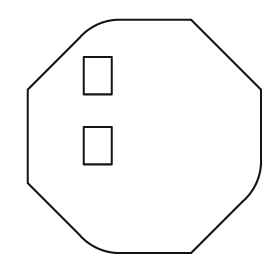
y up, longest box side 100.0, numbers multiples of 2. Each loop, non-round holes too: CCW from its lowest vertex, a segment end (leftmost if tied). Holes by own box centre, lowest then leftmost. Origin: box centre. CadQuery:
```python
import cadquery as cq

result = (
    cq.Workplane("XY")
    .moveTo(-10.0, -50.0)
    .lineTo(20.0, -50.0)
    .lineTo(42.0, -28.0)
    .threePointArc((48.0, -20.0), (50.0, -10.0))
    .lineTo(50.0, 20.0)
    .lineTo(20.0, 50.0)
    .lineTo(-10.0, 50.0)
    .threePointArc((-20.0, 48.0), (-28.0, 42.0))
    .lineTo(-50.0, 20.0)
    .lineTo(-50.0, -20.0)
    .lineTo(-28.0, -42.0)
    .threePointArc((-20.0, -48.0), (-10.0, -50.0))
    .close()
    .moveTo(-26.0, -12.0)
    .lineTo(-14.0, -12.0)
    .lineTo(-14.0, 4.0)
    .lineTo(-26.0, 4.0)
    .close()
    .moveTo(-26.0, 18.0)
    .lineTo(-14.0, 18.0)
    .lineTo(-14.0, 34.0)
    .lineTo(-26.0, 34.0)
    .close()
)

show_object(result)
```